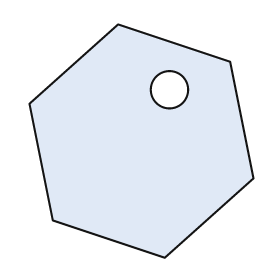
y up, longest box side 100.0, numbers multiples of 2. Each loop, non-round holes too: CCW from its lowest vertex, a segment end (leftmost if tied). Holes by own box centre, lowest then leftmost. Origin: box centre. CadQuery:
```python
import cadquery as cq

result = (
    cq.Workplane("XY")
    .moveTo(10.0, -50.0)
    .lineTo(48.0, -16.0)
    .lineTo(38.0, 34.0)
    .lineTo(-10.0, 50.0)
    .lineTo(-48.0, 16.0)
    .lineTo(-38.0, -34.0)
    .close()
    .moveTo(12.0, 22.0)
    .circle(8.0)
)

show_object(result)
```